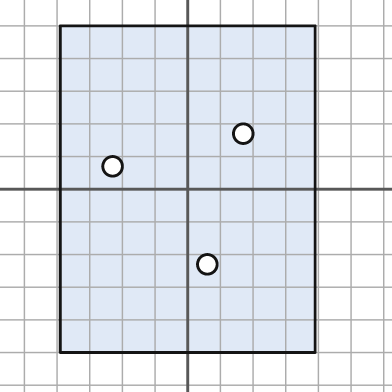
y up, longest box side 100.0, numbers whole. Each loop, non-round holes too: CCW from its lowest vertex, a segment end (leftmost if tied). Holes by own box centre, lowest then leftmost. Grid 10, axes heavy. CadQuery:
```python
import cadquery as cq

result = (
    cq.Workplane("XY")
    .moveTo(-39.0, -50.0)
    .lineTo(39.0, -50.0)
    .lineTo(39.0, 50.0)
    .lineTo(-39.0, 50.0)
    .close()
    .moveTo(6.0, -23.0)
    .circle(3.0)
    .moveTo(-23.0, 7.0)
    .circle(3.0)
    .moveTo(17.0, 17.0)
    .circle(3.0)
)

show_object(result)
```